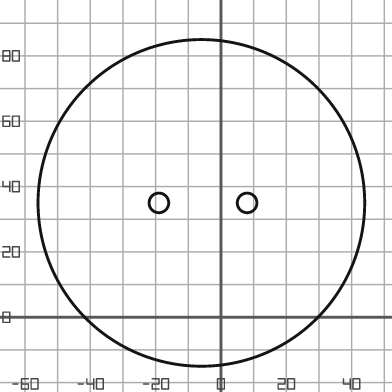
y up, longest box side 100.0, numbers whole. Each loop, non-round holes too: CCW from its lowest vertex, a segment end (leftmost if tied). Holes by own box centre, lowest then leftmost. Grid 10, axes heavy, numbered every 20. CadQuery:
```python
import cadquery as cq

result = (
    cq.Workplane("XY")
    .moveTo(-6.0, 35.0)
    .circle(50.0)
    .moveTo(-19.0, 35.0)
    .circle(3.0)
    .moveTo(8.0, 35.0)
    .circle(3.0)
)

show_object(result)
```